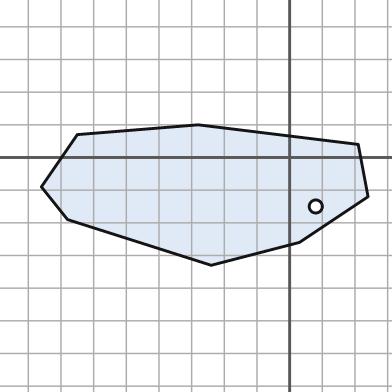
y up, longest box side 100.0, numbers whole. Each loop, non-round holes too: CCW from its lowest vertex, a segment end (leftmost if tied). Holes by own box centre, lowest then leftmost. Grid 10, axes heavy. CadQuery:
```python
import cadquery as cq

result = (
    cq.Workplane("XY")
    .moveTo(-24.0, -33.0)
    .lineTo(3.0, -26.0)
    .lineTo(24.0, -12.0)
    .lineTo(21.0, 4.0)
    .lineTo(-28.0, 10.0)
    .lineTo(-65.0, 7.0)
    .lineTo(-76.0, -9.0)
    .lineTo(-68.0, -19.0)
    .close()
    .moveTo(8.0, -15.0)
    .circle(2.0)
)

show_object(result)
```